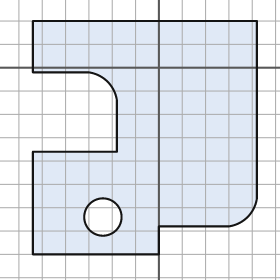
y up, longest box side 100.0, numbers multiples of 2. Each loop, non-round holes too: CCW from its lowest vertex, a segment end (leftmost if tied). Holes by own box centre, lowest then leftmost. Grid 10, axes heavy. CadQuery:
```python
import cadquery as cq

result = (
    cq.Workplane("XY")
    .moveTo(-54.0, -80.0)
    .lineTo(0.0, -80.0)
    .lineTo(0.0, -68.0)
    .lineTo(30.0, -68.0)
    .threePointArc((38.0, -64.0), (42.0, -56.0))
    .lineTo(42.0, 20.0)
    .lineTo(-54.0, 20.0)
    .lineTo(-54.0, -2.0)
    .lineTo(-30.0, -2.0)
    .threePointArc((-22.0, -6.0), (-18.0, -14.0))
    .lineTo(-18.0, -36.0)
    .lineTo(-54.0, -36.0)
    .close()
    .moveTo(-24.0, -64.0)
    .circle(8.0)
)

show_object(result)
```